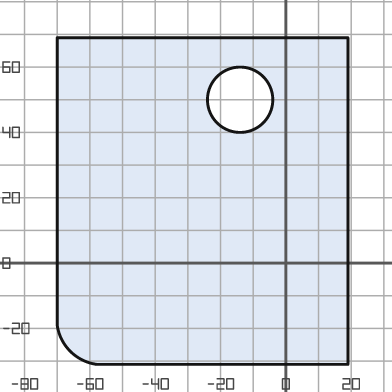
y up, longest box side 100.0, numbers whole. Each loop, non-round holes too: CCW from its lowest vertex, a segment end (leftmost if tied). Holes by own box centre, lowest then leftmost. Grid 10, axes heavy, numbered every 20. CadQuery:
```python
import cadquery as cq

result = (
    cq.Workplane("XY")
    .moveTo(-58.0, -31.0)
    .lineTo(19.0, -31.0)
    .lineTo(19.0, 69.0)
    .lineTo(-70.0, 69.0)
    .lineTo(-70.0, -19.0)
    .threePointArc((-66.0, -27.0), (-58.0, -31.0))
    .close()
    .moveTo(-14.0, 50.0)
    .circle(10.0)
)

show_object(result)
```